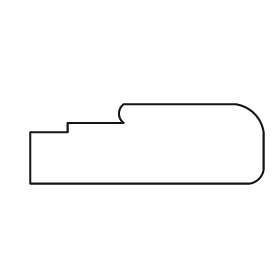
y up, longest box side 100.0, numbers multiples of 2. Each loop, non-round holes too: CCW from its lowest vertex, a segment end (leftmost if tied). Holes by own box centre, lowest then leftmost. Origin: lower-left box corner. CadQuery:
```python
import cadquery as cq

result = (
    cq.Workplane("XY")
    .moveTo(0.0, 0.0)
    .lineTo(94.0, 0.0)
    .threePointArc((98.0, 2.0), (100.0, 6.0))
    .lineTo(100.0, 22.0)
    .threePointArc((96.0, 30.0), (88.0, 34.0))
    .lineTo(40.0, 34.0)
    .threePointArc((38.0, 30.0), (40.0, 26.0))
    .lineTo(16.0, 26.0)
    .lineTo(16.0, 22.0)
    .lineTo(0.0, 22.0)
    .close()
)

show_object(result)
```